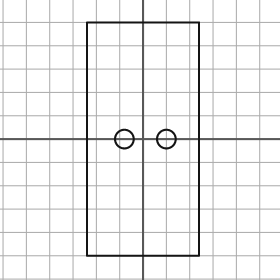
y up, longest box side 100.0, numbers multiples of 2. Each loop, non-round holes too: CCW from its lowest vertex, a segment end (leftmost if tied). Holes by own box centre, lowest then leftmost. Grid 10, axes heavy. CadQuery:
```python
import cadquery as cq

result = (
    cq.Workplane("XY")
    .moveTo(-24.0, -50.0)
    .lineTo(24.0, -50.0)
    .lineTo(24.0, 50.0)
    .lineTo(-24.0, 50.0)
    .close()
    .moveTo(-8.0, 0.0)
    .circle(4.0)
    .moveTo(10.0, 0.0)
    .circle(4.0)
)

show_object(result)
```